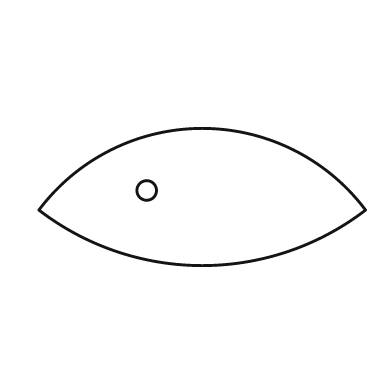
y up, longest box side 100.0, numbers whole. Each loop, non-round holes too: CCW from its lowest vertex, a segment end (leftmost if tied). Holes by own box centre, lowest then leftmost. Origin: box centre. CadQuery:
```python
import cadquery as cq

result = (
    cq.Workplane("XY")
    .moveTo(-50.0, -4.0)
    .threePointArc((0.0, -21.0), (50.0, -4.0))
    .threePointArc((0.0, 21.0), (-50.0, -4.0))
    .close()
    .moveTo(-17.0, 2.0)
    .circle(3.0)
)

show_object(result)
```